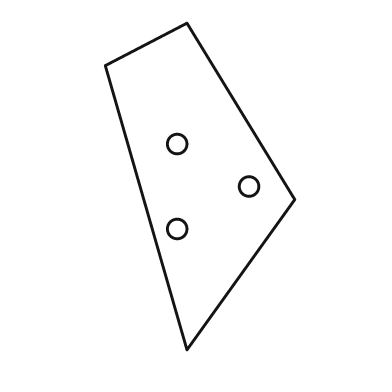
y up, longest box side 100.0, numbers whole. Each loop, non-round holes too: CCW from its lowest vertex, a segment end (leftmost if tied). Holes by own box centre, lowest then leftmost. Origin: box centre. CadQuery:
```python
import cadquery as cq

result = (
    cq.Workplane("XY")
    .moveTo(-4.0, -50.0)
    .lineTo(29.0, -4.0)
    .lineTo(-4.0, 50.0)
    .lineTo(-29.0, 37.0)
    .close()
    .moveTo(-7.0, -13.0)
    .circle(3.0)
    .moveTo(15.0, 0.0)
    .circle(3.0)
    .moveTo(-7.0, 13.0)
    .circle(3.0)
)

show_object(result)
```